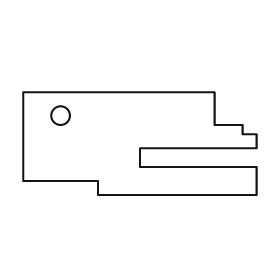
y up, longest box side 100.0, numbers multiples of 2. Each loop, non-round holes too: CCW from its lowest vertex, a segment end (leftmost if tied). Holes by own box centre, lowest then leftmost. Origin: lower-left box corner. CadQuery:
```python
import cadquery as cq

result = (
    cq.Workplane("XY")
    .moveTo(32.0, 0.0)
    .lineTo(100.0, 0.0)
    .lineTo(100.0, 12.0)
    .lineTo(50.0, 12.0)
    .lineTo(50.0, 20.0)
    .lineTo(100.0, 20.0)
    .lineTo(100.0, 26.0)
    .lineTo(94.0, 26.0)
    .lineTo(94.0, 30.0)
    .lineTo(82.0, 30.0)
    .lineTo(82.0, 44.0)
    .lineTo(0.0, 44.0)
    .lineTo(0.0, 6.0)
    .lineTo(32.0, 6.0)
    .close()
    .moveTo(16.0, 34.0)
    .circle(4.0)
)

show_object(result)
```